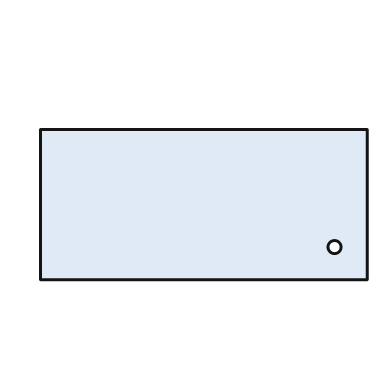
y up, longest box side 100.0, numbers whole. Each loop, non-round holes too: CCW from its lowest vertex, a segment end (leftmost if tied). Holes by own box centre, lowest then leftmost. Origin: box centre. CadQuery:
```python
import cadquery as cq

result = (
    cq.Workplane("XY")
    .moveTo(-50.0, -23.0)
    .lineTo(50.0, -23.0)
    .lineTo(50.0, 23.0)
    .lineTo(-50.0, 23.0)
    .close()
    .moveTo(40.0, -13.0)
    .circle(2.0)
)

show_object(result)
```